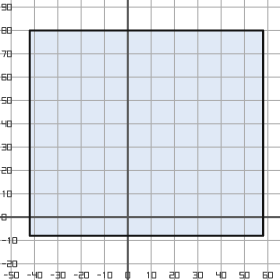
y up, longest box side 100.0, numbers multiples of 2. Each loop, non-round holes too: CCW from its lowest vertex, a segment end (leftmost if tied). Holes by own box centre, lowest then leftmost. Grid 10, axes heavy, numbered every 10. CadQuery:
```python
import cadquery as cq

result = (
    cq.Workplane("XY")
    .moveTo(-42.0, -8.0)
    .lineTo(58.0, -8.0)
    .lineTo(58.0, 80.0)
    .lineTo(-42.0, 80.0)
    .close()
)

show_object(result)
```